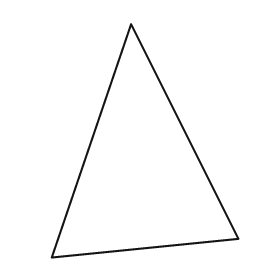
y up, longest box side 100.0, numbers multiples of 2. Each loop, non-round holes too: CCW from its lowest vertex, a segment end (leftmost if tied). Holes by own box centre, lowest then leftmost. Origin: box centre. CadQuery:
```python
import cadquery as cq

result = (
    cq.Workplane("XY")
    .moveTo(-40.0, -50.0)
    .lineTo(40.0, -42.0)
    .lineTo(-6.0, 50.0)
    .close()
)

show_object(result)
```